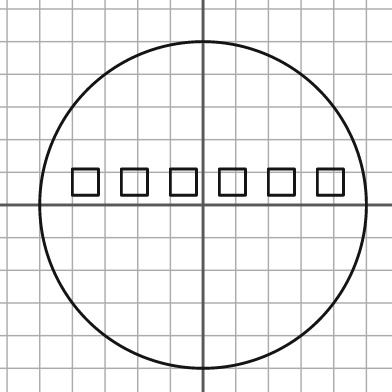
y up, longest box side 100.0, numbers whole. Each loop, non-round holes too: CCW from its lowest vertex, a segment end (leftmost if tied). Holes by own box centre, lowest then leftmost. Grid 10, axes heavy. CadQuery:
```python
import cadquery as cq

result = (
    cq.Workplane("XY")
    .moveTo(0.0, 0.0)
    .circle(50.0)
    .moveTo(-40.0, 3.0)
    .lineTo(-32.0, 3.0)
    .lineTo(-32.0, 11.0)
    .lineTo(-40.0, 11.0)
    .close()
    .moveTo(-25.0, 3.0)
    .lineTo(-17.0, 3.0)
    .lineTo(-17.0, 11.0)
    .lineTo(-25.0, 11.0)
    .close()
    .moveTo(-10.0, 3.0)
    .lineTo(-2.0, 3.0)
    .lineTo(-2.0, 11.0)
    .lineTo(-10.0, 11.0)
    .close()
    .moveTo(5.0, 3.0)
    .lineTo(13.0, 3.0)
    .lineTo(13.0, 11.0)
    .lineTo(5.0, 11.0)
    .close()
    .moveTo(20.0, 3.0)
    .lineTo(28.0, 3.0)
    .lineTo(28.0, 11.0)
    .lineTo(20.0, 11.0)
    .close()
    .moveTo(35.0, 3.0)
    .lineTo(43.0, 3.0)
    .lineTo(43.0, 11.0)
    .lineTo(35.0, 11.0)
    .close()
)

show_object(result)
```